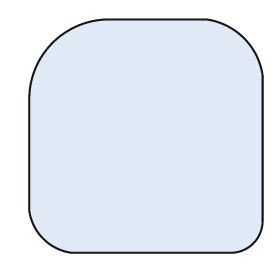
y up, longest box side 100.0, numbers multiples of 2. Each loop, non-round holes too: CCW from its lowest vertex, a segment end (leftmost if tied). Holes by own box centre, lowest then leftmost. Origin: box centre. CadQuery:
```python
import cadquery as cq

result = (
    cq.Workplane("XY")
    .moveTo(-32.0, -50.0)
    .lineTo(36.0, -50.0)
    .threePointArc((46.0, -46.0), (50.0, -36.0))
    .lineTo(50.0, 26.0)
    .threePointArc((42.0, 42.0), (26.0, 50.0))
    .lineTo(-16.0, 50.0)
    .threePointArc((-40.0, 40.0), (-50.0, 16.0))
    .lineTo(-50.0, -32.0)
    .threePointArc((-44.0, -44.0), (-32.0, -50.0))
    .close()
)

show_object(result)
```